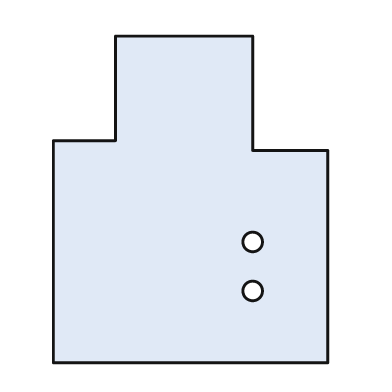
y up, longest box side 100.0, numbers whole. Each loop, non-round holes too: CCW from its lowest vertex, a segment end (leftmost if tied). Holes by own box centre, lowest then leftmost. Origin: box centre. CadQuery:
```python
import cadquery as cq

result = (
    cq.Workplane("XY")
    .moveTo(-42.0, -50.0)
    .lineTo(42.0, -50.0)
    .lineTo(42.0, 15.0)
    .lineTo(19.0, 15.0)
    .lineTo(19.0, 50.0)
    .lineTo(-23.0, 50.0)
    .lineTo(-23.0, 18.0)
    .lineTo(-42.0, 18.0)
    .close()
    .moveTo(19.0, -28.0)
    .circle(3.0)
    .moveTo(19.0, -13.0)
    .circle(3.0)
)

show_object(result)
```